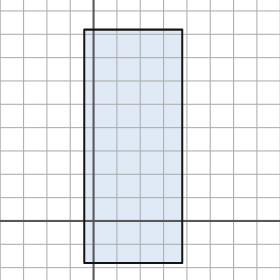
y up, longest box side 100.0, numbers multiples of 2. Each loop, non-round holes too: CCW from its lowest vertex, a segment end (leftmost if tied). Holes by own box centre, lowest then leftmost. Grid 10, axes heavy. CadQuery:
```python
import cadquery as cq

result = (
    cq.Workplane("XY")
    .moveTo(-4.0, -18.0)
    .lineTo(38.0, -18.0)
    .lineTo(38.0, 82.0)
    .lineTo(-4.0, 82.0)
    .close()
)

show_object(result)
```